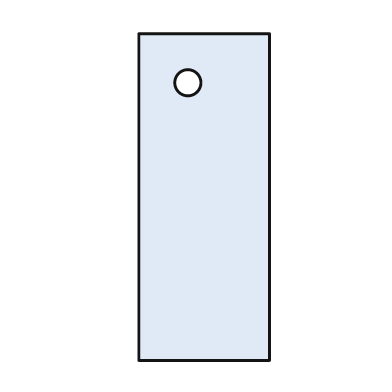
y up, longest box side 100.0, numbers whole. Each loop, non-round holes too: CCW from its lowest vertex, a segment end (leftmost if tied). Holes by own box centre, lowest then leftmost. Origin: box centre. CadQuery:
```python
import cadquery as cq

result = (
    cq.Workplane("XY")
    .moveTo(-20.0, -50.0)
    .lineTo(20.0, -50.0)
    .lineTo(20.0, 50.0)
    .lineTo(-20.0, 50.0)
    .close()
    .moveTo(-5.0, 35.0)
    .circle(4.0)
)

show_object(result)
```